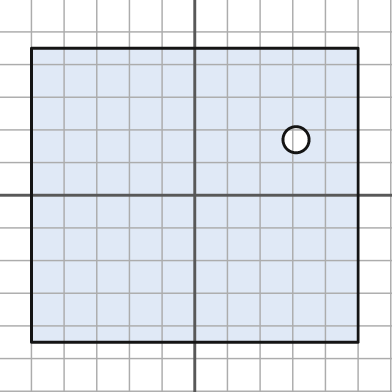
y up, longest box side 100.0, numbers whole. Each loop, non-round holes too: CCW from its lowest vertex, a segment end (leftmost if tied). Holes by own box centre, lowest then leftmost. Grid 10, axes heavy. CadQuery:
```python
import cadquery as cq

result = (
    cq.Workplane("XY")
    .moveTo(-50.0, -45.0)
    .lineTo(50.0, -45.0)
    .lineTo(50.0, 45.0)
    .lineTo(-50.0, 45.0)
    .close()
    .moveTo(31.0, 17.0)
    .circle(4.0)
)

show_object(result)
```